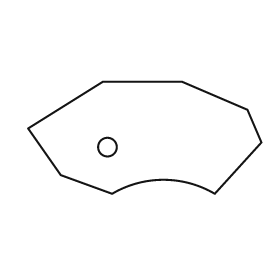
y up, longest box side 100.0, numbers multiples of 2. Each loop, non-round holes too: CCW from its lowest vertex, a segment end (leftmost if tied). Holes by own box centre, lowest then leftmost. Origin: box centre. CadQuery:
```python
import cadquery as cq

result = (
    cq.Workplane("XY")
    .moveTo(-14.0, -24.0)
    .threePointArc((8.0, -18.0), (30.0, -24.0))
    .lineTo(50.0, -2.0)
    .lineTo(44.0, 12.0)
    .lineTo(16.0, 24.0)
    .lineTo(-18.0, 24.0)
    .lineTo(-50.0, 4.0)
    .lineTo(-36.0, -16.0)
    .close()
    .moveTo(-16.0, -4.0)
    .circle(4.0)
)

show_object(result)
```